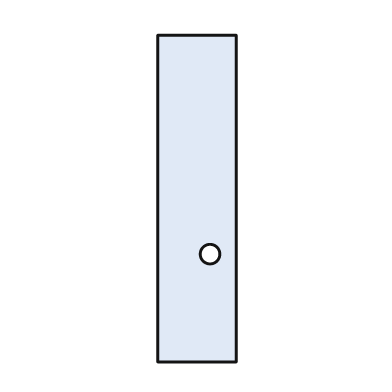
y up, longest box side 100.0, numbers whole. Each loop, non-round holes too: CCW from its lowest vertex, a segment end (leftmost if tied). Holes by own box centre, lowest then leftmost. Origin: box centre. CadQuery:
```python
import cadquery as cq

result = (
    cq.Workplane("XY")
    .moveTo(-12.0, -50.0)
    .lineTo(12.0, -50.0)
    .lineTo(12.0, 50.0)
    .lineTo(-12.0, 50.0)
    .close()
    .moveTo(4.0, -17.0)
    .circle(3.0)
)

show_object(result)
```